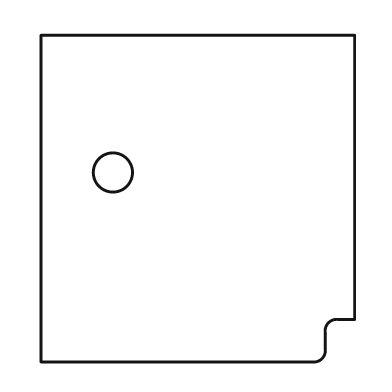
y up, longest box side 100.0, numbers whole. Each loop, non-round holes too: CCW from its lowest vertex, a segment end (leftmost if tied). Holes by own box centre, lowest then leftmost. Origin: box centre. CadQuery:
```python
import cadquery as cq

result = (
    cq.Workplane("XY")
    .moveTo(-48.0, -50.0)
    .lineTo(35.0, -50.0)
    .threePointArc((38.0, -49.0), (39.0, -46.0))
    .lineTo(39.0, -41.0)
    .threePointArc((40.0, -38.0), (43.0, -37.0))
    .lineTo(48.0, -37.0)
    .lineTo(48.0, 50.0)
    .lineTo(-48.0, 50.0)
    .close()
    .moveTo(-26.0, 8.0)
    .circle(6.0)
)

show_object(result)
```